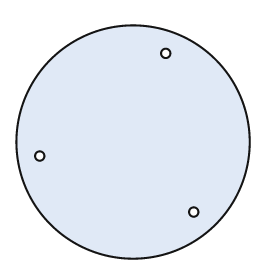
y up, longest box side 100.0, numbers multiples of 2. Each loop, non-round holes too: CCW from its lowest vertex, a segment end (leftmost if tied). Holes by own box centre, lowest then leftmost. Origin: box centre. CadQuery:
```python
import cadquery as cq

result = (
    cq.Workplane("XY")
    .moveTo(0.0, 0.0)
    .circle(50.0)
    .moveTo(26.0, -30.0)
    .circle(2.0)
    .moveTo(-40.0, -6.0)
    .circle(2.0)
    .moveTo(14.0, 38.0)
    .circle(2.0)
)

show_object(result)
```